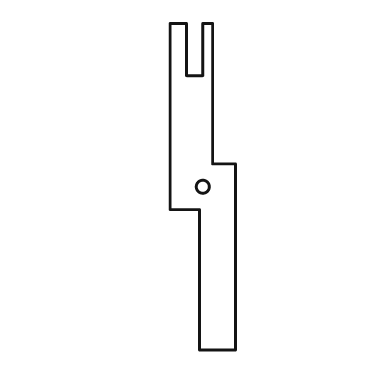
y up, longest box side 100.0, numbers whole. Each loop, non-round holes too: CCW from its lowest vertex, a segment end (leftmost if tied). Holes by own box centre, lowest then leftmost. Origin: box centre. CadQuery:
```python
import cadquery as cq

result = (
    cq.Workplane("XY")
    .moveTo(-1.0, -50.0)
    .lineTo(10.0, -50.0)
    .lineTo(10.0, 7.0)
    .lineTo(3.0, 7.0)
    .lineTo(3.0, 50.0)
    .lineTo(0.0, 50.0)
    .lineTo(0.0, 34.0)
    .lineTo(-5.0, 34.0)
    .lineTo(-5.0, 50.0)
    .lineTo(-10.0, 50.0)
    .lineTo(-10.0, -7.0)
    .lineTo(-1.0, -7.0)
    .close()
    .moveTo(0.0, 0.0)
    .circle(2.0)
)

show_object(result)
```